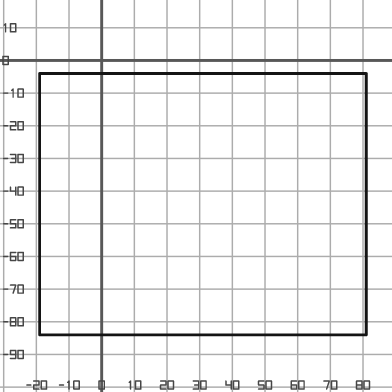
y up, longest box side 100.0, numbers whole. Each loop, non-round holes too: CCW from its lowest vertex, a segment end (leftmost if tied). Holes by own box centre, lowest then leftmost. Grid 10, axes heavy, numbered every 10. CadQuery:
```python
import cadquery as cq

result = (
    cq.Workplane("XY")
    .moveTo(-19.0, -84.0)
    .lineTo(81.0, -84.0)
    .lineTo(81.0, -4.0)
    .lineTo(-19.0, -4.0)
    .close()
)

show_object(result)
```